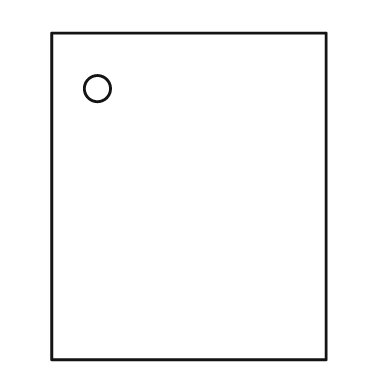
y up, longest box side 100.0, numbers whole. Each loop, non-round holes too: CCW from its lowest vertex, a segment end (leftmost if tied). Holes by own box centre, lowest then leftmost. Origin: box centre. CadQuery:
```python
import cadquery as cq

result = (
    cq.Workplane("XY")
    .moveTo(-42.0, -50.0)
    .lineTo(42.0, -50.0)
    .lineTo(42.0, 50.0)
    .lineTo(-42.0, 50.0)
    .close()
    .moveTo(-28.0, 33.0)
    .circle(4.0)
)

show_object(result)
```